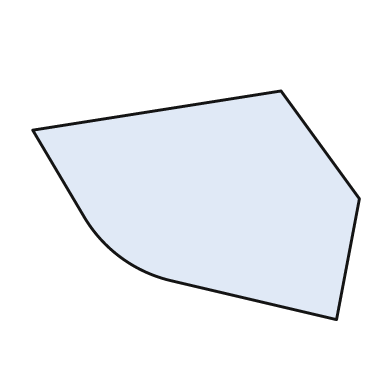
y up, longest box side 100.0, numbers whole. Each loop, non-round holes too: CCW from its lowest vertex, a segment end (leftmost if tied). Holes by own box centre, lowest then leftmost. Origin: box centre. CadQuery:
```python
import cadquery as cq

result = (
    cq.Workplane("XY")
    .moveTo(43.0, -35.0)
    .lineTo(50.0, 2.0)
    .lineTo(26.0, 35.0)
    .lineTo(-50.0, 23.0)
    .lineTo(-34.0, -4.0)
    .threePointArc((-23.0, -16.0), (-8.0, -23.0))
    .close()
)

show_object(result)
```